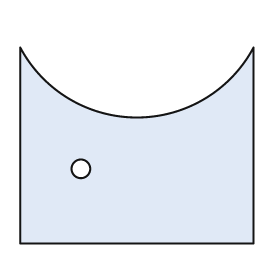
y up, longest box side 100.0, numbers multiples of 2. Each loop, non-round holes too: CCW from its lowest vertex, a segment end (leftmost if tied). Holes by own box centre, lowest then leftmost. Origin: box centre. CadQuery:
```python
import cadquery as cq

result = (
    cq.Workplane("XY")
    .moveTo(-50.0, -42.0)
    .lineTo(50.0, -42.0)
    .lineTo(50.0, 42.0)
    .threePointArc((0.0, 12.0), (-50.0, 42.0))
    .close()
    .moveTo(-24.0, -10.0)
    .circle(4.0)
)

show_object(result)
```